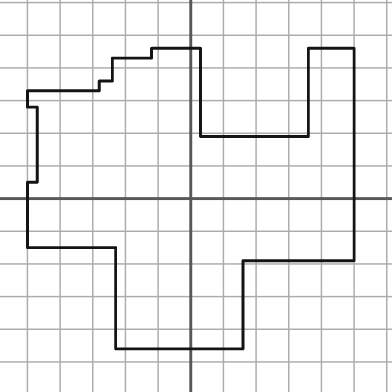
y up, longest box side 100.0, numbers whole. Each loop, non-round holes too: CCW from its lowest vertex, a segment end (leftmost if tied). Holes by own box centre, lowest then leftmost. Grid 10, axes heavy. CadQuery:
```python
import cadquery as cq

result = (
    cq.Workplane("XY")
    .moveTo(-23.0, -46.0)
    .lineTo(16.0, -46.0)
    .lineTo(16.0, -19.0)
    .lineTo(50.0, -19.0)
    .lineTo(50.0, 46.0)
    .lineTo(36.0, 46.0)
    .lineTo(36.0, 19.0)
    .lineTo(3.0, 19.0)
    .lineTo(3.0, 46.0)
    .lineTo(-12.0, 46.0)
    .lineTo(-12.0, 43.0)
    .lineTo(-24.0, 43.0)
    .lineTo(-24.0, 36.0)
    .lineTo(-28.0, 36.0)
    .lineTo(-28.0, 33.0)
    .lineTo(-50.0, 33.0)
    .lineTo(-50.0, 28.0)
    .lineTo(-47.0, 28.0)
    .lineTo(-47.0, 5.0)
    .lineTo(-50.0, 5.0)
    .lineTo(-50.0, -15.0)
    .lineTo(-23.0, -15.0)
    .close()
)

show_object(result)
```